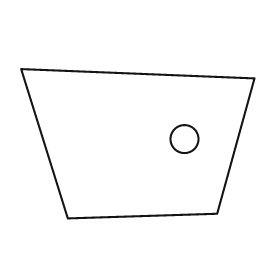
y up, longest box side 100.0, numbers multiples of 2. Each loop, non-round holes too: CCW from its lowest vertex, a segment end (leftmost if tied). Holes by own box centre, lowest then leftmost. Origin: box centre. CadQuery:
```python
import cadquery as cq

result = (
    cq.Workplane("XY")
    .moveTo(-30.0, -32.0)
    .lineTo(34.0, -30.0)
    .lineTo(50.0, 28.0)
    .lineTo(-50.0, 32.0)
    .close()
    .moveTo(20.0, 2.0)
    .circle(6.0)
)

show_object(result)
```